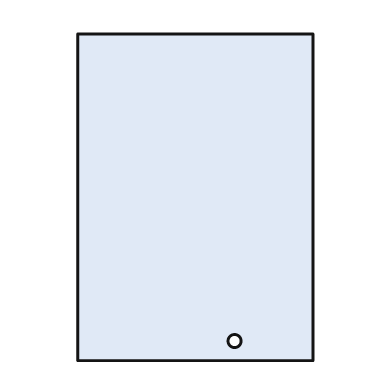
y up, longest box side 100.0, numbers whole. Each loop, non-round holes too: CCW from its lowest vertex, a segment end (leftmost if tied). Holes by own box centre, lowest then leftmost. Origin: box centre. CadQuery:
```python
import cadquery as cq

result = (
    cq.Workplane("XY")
    .moveTo(-36.0, -50.0)
    .lineTo(36.0, -50.0)
    .lineTo(36.0, 50.0)
    .lineTo(-36.0, 50.0)
    .close()
    .moveTo(12.0, -44.0)
    .circle(2.0)
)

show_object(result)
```